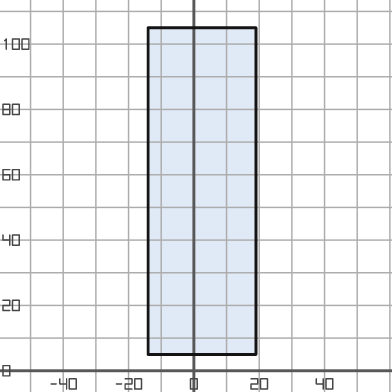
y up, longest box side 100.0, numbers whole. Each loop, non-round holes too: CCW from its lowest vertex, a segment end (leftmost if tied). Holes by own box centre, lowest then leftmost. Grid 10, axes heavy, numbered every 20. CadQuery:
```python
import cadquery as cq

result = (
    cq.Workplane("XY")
    .moveTo(-14.0, 5.0)
    .lineTo(19.0, 5.0)
    .lineTo(19.0, 105.0)
    .lineTo(-14.0, 105.0)
    .close()
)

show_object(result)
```